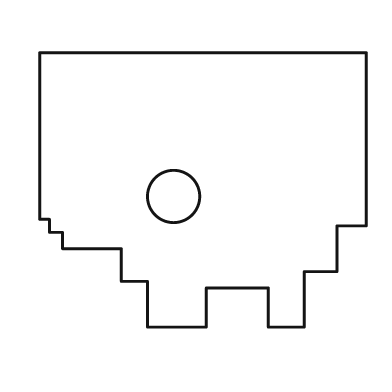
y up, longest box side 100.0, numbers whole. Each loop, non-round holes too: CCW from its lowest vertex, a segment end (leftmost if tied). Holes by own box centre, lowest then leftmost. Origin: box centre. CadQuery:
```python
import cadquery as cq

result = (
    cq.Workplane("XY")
    .moveTo(-17.0, -42.0)
    .lineTo(1.0, -42.0)
    .lineTo(1.0, -30.0)
    .lineTo(20.0, -30.0)
    .lineTo(20.0, -42.0)
    .lineTo(31.0, -42.0)
    .lineTo(31.0, -25.0)
    .lineTo(41.0, -25.0)
    .lineTo(41.0, -11.0)
    .lineTo(50.0, -11.0)
    .lineTo(50.0, 42.0)
    .lineTo(-50.0, 42.0)
    .lineTo(-50.0, -9.0)
    .lineTo(-47.0, -9.0)
    .lineTo(-47.0, -13.0)
    .lineTo(-43.0, -13.0)
    .lineTo(-43.0, -18.0)
    .lineTo(-25.0, -18.0)
    .lineTo(-25.0, -28.0)
    .lineTo(-17.0, -28.0)
    .close()
    .moveTo(-9.0, -2.0)
    .circle(8.0)
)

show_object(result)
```